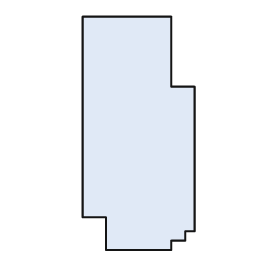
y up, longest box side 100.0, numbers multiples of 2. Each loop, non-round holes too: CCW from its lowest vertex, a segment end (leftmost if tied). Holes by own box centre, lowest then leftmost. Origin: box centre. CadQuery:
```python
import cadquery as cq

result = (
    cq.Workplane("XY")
    .moveTo(-14.0, -50.0)
    .lineTo(14.0, -50.0)
    .lineTo(14.0, -46.0)
    .lineTo(20.0, -46.0)
    .lineTo(20.0, -42.0)
    .lineTo(24.0, -42.0)
    .lineTo(24.0, 20.0)
    .lineTo(14.0, 20.0)
    .lineTo(14.0, 50.0)
    .lineTo(-24.0, 50.0)
    .lineTo(-24.0, -36.0)
    .lineTo(-14.0, -36.0)
    .close()
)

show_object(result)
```